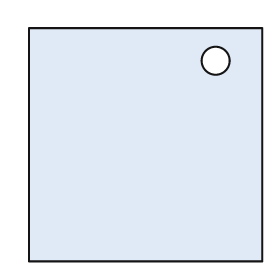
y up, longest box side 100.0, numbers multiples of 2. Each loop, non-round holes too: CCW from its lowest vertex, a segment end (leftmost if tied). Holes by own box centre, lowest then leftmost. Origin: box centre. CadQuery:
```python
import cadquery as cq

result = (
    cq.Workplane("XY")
    .moveTo(-50.0, -50.0)
    .lineTo(50.0, -50.0)
    .lineTo(50.0, 50.0)
    .lineTo(-50.0, 50.0)
    .close()
    .moveTo(30.0, 36.0)
    .circle(6.0)
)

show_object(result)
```